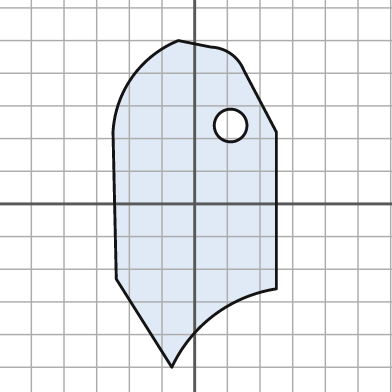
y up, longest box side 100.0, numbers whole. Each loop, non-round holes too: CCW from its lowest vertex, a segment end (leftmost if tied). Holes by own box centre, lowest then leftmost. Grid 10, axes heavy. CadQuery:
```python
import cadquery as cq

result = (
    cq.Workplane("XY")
    .moveTo(-7.0, -50.0)
    .threePointArc((6.0, -34.0), (25.0, -26.0))
    .lineTo(25.0, 22.0)
    .lineTo(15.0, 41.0)
    .threePointArc((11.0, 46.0), (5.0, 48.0))
    .lineTo(-5.0, 50.0)
    .threePointArc((-19.0, 39.0), (-25.0, 22.0))
    .lineTo(-24.0, -23.0)
    .close()
    .moveTo(11.0, 24.0)
    .circle(5.0)
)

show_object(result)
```